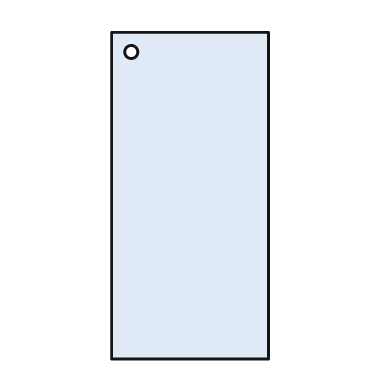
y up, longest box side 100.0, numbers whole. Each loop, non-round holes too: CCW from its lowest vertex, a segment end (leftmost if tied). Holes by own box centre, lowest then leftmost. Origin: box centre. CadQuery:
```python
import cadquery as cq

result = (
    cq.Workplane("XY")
    .moveTo(-24.0, -50.0)
    .lineTo(24.0, -50.0)
    .lineTo(24.0, 50.0)
    .lineTo(-24.0, 50.0)
    .close()
    .moveTo(-18.0, 44.0)
    .circle(2.0)
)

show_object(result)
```